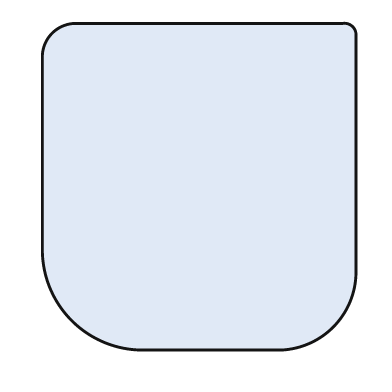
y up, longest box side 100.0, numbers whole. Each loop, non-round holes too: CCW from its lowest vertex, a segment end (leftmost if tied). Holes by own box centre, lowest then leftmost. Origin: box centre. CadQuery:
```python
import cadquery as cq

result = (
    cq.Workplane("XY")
    .moveTo(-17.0, -50.0)
    .lineTo(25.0, -50.0)
    .threePointArc((41.0, -43.0), (48.0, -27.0))
    .lineTo(48.0, 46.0)
    .threePointArc((47.0, 49.0), (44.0, 50.0))
    .lineTo(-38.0, 50.0)
    .threePointArc((-45.0, 47.0), (-48.0, 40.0))
    .lineTo(-48.0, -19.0)
    .threePointArc((-39.0, -41.0), (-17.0, -50.0))
    .close()
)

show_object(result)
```